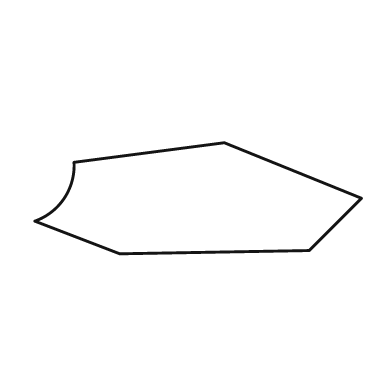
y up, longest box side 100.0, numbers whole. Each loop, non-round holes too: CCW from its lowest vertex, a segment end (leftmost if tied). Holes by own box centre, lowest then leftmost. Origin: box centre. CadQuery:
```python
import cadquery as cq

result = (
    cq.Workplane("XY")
    .moveTo(-24.0, -17.0)
    .lineTo(34.0, -16.0)
    .lineTo(50.0, 0.0)
    .lineTo(8.0, 17.0)
    .lineTo(-38.0, 11.0)
    .threePointArc((-41.0, 0.0), (-50.0, -7.0))
    .close()
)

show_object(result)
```